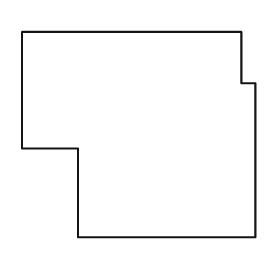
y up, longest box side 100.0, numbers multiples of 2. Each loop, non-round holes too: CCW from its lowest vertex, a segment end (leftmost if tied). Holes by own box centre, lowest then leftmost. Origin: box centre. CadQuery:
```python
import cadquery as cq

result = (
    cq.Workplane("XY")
    .moveTo(-26.0, -44.0)
    .lineTo(50.0, -44.0)
    .lineTo(50.0, 22.0)
    .lineTo(44.0, 22.0)
    .lineTo(44.0, 44.0)
    .lineTo(-50.0, 44.0)
    .lineTo(-50.0, -6.0)
    .lineTo(-26.0, -6.0)
    .close()
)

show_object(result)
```